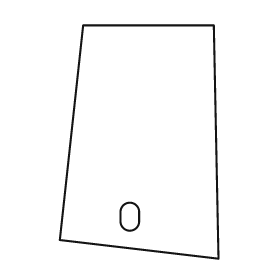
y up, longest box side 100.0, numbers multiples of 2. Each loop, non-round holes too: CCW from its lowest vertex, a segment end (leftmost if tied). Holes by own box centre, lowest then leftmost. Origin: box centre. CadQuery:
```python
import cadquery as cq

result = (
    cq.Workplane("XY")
    .moveTo(34.0, -50.0)
    .lineTo(32.0, 50.0)
    .lineTo(-24.0, 50.0)
    .lineTo(-34.0, -42.0)
    .close()
    .moveTo(-8.0, -34.0)
    .threePointArc((-4.0, -38.0), (0.0, -34.0))
    .lineTo(0.0, -30.0)
    .threePointArc((-4.0, -26.0), (-8.0, -30.0))
    .close()
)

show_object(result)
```